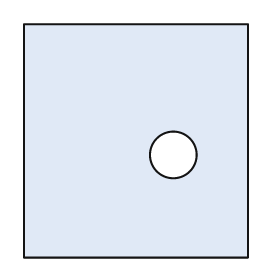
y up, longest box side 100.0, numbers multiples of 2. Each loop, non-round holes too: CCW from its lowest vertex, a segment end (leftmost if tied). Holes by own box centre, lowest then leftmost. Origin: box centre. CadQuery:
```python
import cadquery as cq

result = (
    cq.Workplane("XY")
    .moveTo(-48.0, -50.0)
    .lineTo(48.0, -50.0)
    .lineTo(48.0, 50.0)
    .lineTo(-48.0, 50.0)
    .close()
    .moveTo(16.0, -6.0)
    .circle(10.0)
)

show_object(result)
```